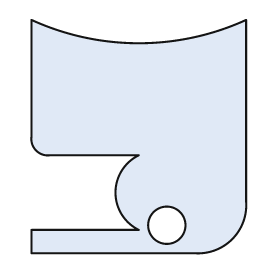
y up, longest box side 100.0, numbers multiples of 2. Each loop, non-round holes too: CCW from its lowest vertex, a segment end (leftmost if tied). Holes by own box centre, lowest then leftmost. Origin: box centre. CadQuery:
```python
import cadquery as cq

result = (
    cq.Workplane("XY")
    .moveTo(-46.0, -50.0)
    .lineTo(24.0, -50.0)
    .threePointArc((40.0, -44.0), (46.0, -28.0))
    .lineTo(46.0, 50.0)
    .threePointArc((0.0, 40.0), (-46.0, 50.0))
    .lineTo(-46.0, 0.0)
    .threePointArc((-44.0, -6.0), (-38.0, -8.0))
    .lineTo(0.0, -8.0)
    .threePointArc((-10.0, -24.0), (0.0, -40.0))
    .lineTo(-46.0, -40.0)
    .close()
    .moveTo(12.0, -38.0)
    .circle(8.0)
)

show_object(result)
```